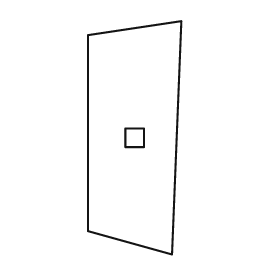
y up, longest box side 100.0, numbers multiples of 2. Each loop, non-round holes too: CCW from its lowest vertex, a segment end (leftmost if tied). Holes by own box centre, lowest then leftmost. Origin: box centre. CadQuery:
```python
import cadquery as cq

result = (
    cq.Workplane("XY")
    .moveTo(16.0, -50.0)
    .lineTo(20.0, 50.0)
    .lineTo(-20.0, 44.0)
    .lineTo(-20.0, -40.0)
    .close()
    .moveTo(-4.0, -4.0)
    .lineTo(4.0, -4.0)
    .lineTo(4.0, 4.0)
    .lineTo(-4.0, 4.0)
    .close()
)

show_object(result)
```